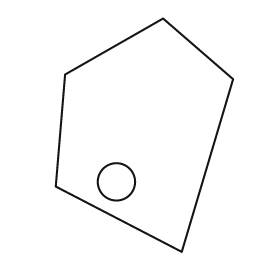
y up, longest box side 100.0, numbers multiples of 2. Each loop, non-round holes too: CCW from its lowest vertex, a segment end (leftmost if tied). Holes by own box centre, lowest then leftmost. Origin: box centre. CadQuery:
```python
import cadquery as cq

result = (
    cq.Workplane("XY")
    .moveTo(16.0, -50.0)
    .lineTo(38.0, 24.0)
    .lineTo(8.0, 50.0)
    .lineTo(-34.0, 26.0)
    .lineTo(-38.0, -22.0)
    .close()
    .moveTo(-12.0, -20.0)
    .circle(8.0)
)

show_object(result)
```